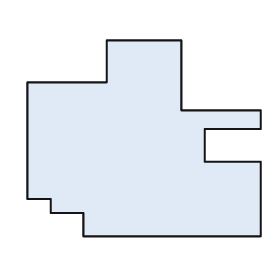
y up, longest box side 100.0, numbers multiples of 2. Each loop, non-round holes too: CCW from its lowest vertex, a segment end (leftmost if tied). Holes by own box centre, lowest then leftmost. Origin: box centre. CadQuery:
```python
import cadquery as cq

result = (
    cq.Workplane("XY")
    .moveTo(-26.0, -42.0)
    .lineTo(50.0, -42.0)
    .lineTo(50.0, -10.0)
    .lineTo(26.0, -10.0)
    .lineTo(26.0, 4.0)
    .lineTo(50.0, 4.0)
    .lineTo(50.0, 12.0)
    .lineTo(16.0, 12.0)
    .lineTo(16.0, 42.0)
    .lineTo(-16.0, 42.0)
    .lineTo(-16.0, 24.0)
    .lineTo(-50.0, 24.0)
    .lineTo(-50.0, -26.0)
    .lineTo(-40.0, -26.0)
    .lineTo(-40.0, -32.0)
    .lineTo(-26.0, -32.0)
    .close()
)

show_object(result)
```